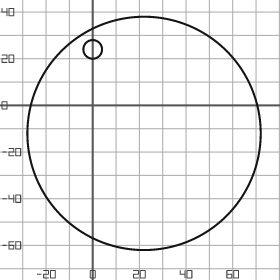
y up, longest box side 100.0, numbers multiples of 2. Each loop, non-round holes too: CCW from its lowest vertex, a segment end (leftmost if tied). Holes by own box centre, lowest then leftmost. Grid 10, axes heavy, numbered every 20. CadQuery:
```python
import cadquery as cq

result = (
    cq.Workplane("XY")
    .moveTo(22.0, -12.0)
    .circle(50.0)
    .moveTo(0.0, 24.0)
    .circle(4.0)
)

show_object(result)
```